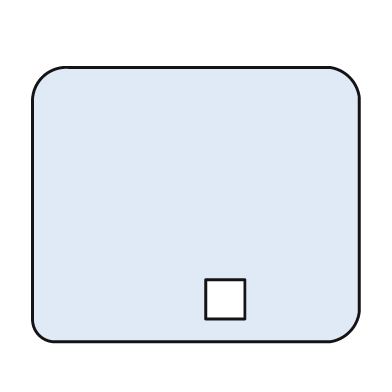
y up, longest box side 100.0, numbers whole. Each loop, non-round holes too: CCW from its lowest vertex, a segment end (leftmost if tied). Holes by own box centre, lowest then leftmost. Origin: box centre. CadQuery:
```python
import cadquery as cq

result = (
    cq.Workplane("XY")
    .moveTo(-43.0, -42.0)
    .lineTo(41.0, -42.0)
    .threePointArc((47.0, -39.0), (50.0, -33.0))
    .lineTo(50.0, 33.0)
    .threePointArc((47.0, 39.0), (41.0, 42.0))
    .lineTo(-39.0, 42.0)
    .threePointArc((-47.0, 39.0), (-50.0, 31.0))
    .lineTo(-50.0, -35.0)
    .threePointArc((-48.0, -40.0), (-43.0, -42.0))
    .close()
    .moveTo(3.0, -35.0)
    .lineTo(15.0, -35.0)
    .lineTo(15.0, -23.0)
    .lineTo(3.0, -23.0)
    .close()
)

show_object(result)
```